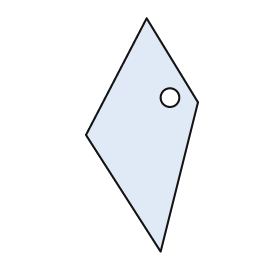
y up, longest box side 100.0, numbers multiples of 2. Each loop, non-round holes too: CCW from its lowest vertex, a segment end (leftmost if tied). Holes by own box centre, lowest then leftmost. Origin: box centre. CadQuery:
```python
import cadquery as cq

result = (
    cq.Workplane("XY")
    .moveTo(8.0, -50.0)
    .lineTo(24.0, 14.0)
    .lineTo(2.0, 50.0)
    .lineTo(-24.0, 0.0)
    .close()
    .moveTo(12.0, 16.0)
    .circle(4.0)
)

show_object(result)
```